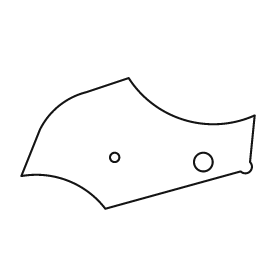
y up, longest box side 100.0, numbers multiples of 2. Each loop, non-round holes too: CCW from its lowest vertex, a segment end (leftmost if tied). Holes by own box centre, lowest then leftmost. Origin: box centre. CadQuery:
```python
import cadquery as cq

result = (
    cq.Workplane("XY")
    .moveTo(-14.0, -28.0)
    .lineTo(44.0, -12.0)
    .threePointArc((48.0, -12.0), (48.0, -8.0))
    .lineTo(50.0, 12.0)
    .threePointArc((20.0, 10.0), (-4.0, 28.0))
    .lineTo(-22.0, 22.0)
    .threePointArc((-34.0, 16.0), (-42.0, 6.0))
    .lineTo(-50.0, -14.0)
    .threePointArc((-30.0, -16.0), (-14.0, -28.0))
    .close()
    .moveTo(28.0, -8.0)
    .circle(4.0)
    .moveTo(-10.0, -6.0)
    .circle(2.0)
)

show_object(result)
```